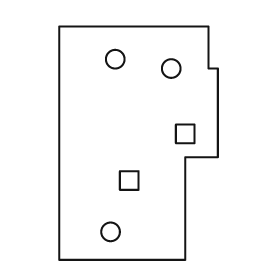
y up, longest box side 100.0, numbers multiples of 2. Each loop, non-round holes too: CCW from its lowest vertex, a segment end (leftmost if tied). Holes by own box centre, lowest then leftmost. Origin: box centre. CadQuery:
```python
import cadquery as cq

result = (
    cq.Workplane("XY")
    .moveTo(-34.0, -50.0)
    .lineTo(20.0, -50.0)
    .lineTo(20.0, -6.0)
    .lineTo(34.0, -6.0)
    .lineTo(34.0, 32.0)
    .lineTo(30.0, 32.0)
    .lineTo(30.0, 50.0)
    .lineTo(-34.0, 50.0)
    .close()
    .moveTo(-12.0, -38.0)
    .circle(4.0)
    .moveTo(-8.0, -20.0)
    .lineTo(0.0, -20.0)
    .lineTo(0.0, -12.0)
    .lineTo(-8.0, -12.0)
    .close()
    .moveTo(16.0, 0.0)
    .lineTo(24.0, 0.0)
    .lineTo(24.0, 8.0)
    .lineTo(16.0, 8.0)
    .close()
    .moveTo(14.0, 32.0)
    .circle(4.0)
    .moveTo(-10.0, 36.0)
    .circle(4.0)
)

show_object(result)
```